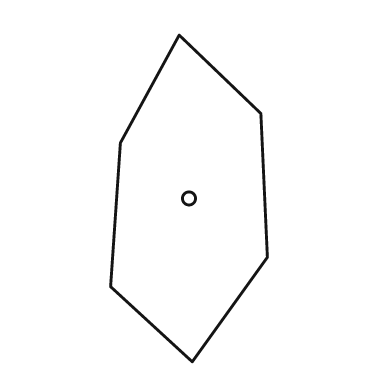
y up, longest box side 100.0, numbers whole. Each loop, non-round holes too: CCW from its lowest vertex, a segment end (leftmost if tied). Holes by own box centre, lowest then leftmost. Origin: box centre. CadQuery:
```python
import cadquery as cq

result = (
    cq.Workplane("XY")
    .moveTo(1.0, -50.0)
    .lineTo(24.0, -18.0)
    .lineTo(22.0, 26.0)
    .lineTo(-3.0, 50.0)
    .lineTo(-21.0, 17.0)
    .lineTo(-24.0, -27.0)
    .close()
    .moveTo(0.0, 0.0)
    .circle(2.0)
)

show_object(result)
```